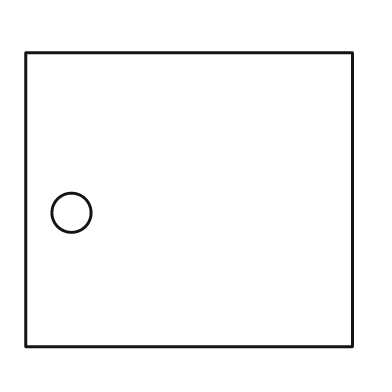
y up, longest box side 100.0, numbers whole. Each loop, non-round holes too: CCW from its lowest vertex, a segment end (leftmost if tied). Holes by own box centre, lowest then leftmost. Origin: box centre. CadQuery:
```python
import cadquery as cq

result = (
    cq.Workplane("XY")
    .moveTo(-50.0, -45.0)
    .lineTo(50.0, -45.0)
    .lineTo(50.0, 45.0)
    .lineTo(-50.0, 45.0)
    .close()
    .moveTo(-36.0, -4.0)
    .circle(6.0)
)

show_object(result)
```